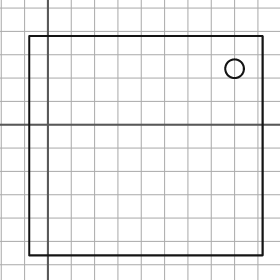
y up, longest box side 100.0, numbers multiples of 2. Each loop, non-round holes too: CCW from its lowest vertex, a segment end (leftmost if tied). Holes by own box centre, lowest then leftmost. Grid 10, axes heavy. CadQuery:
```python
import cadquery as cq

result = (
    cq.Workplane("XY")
    .moveTo(-8.0, -56.0)
    .lineTo(92.0, -56.0)
    .lineTo(92.0, 38.0)
    .lineTo(-8.0, 38.0)
    .close()
    .moveTo(80.0, 24.0)
    .circle(4.0)
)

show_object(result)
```